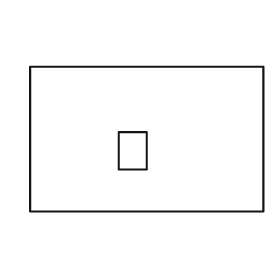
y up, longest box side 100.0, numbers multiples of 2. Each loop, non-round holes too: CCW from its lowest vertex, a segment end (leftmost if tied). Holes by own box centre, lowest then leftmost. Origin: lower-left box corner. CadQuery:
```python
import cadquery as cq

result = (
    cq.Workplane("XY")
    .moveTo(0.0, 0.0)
    .lineTo(100.0, 0.0)
    .lineTo(100.0, 62.0)
    .lineTo(0.0, 62.0)
    .close()
    .moveTo(38.0, 18.0)
    .lineTo(50.0, 18.0)
    .lineTo(50.0, 34.0)
    .lineTo(38.0, 34.0)
    .close()
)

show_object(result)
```